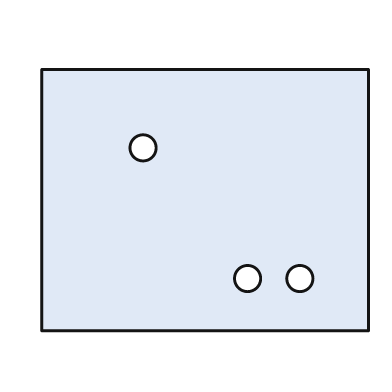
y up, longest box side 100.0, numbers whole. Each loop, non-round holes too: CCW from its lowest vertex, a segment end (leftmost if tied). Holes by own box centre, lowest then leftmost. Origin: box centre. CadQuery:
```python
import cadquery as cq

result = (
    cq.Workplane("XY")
    .moveTo(-50.0, -40.0)
    .lineTo(50.0, -40.0)
    .lineTo(50.0, 40.0)
    .lineTo(-50.0, 40.0)
    .close()
    .moveTo(13.0, -24.0)
    .circle(4.0)
    .moveTo(29.0, -24.0)
    .circle(4.0)
    .moveTo(-19.0, 16.0)
    .circle(4.0)
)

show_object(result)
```